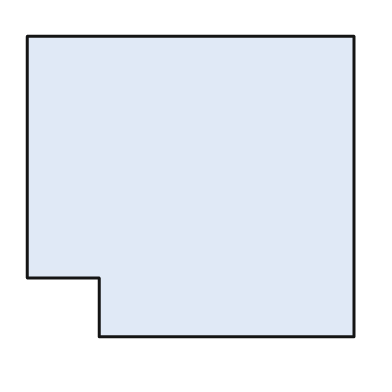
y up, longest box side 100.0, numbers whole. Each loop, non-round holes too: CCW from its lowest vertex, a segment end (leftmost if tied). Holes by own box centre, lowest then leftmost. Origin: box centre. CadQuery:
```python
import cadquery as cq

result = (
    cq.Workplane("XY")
    .moveTo(-28.0, -46.0)
    .lineTo(50.0, -46.0)
    .lineTo(50.0, 46.0)
    .lineTo(-50.0, 46.0)
    .lineTo(-50.0, -28.0)
    .lineTo(-28.0, -28.0)
    .close()
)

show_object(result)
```